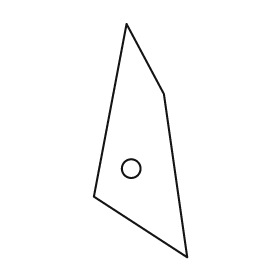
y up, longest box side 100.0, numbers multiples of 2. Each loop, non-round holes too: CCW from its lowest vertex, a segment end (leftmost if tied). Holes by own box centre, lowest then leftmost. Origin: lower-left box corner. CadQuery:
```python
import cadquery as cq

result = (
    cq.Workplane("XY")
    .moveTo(40.0, 0.0)
    .lineTo(30.0, 70.0)
    .lineTo(14.0, 100.0)
    .lineTo(0.0, 26.0)
    .close()
    .moveTo(16.0, 38.0)
    .circle(4.0)
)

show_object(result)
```